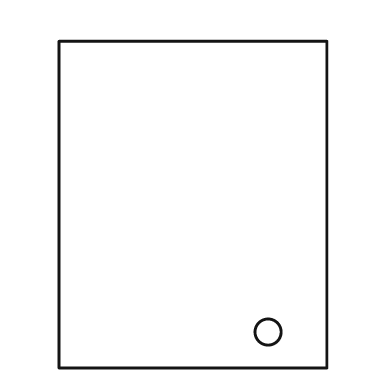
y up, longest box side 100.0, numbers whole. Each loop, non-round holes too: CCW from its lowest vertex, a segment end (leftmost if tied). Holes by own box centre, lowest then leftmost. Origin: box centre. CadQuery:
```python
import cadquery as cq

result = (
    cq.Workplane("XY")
    .moveTo(-41.0, -50.0)
    .lineTo(41.0, -50.0)
    .lineTo(41.0, 50.0)
    .lineTo(-41.0, 50.0)
    .close()
    .moveTo(23.0, -39.0)
    .circle(4.0)
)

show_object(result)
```